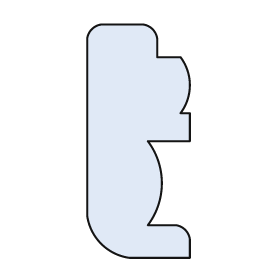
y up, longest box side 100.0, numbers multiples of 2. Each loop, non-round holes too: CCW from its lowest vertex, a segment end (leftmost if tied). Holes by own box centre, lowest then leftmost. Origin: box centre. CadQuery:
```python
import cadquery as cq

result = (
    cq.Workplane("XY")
    .moveTo(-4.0, -50.0)
    .lineTo(22.0, -50.0)
    .lineTo(22.0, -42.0)
    .threePointArc((20.0, -38.0), (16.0, -36.0))
    .lineTo(4.0, -36.0)
    .threePointArc((10.0, -18.0), (4.0, 0.0))
    .lineTo(22.0, 0.0)
    .lineTo(22.0, 12.0)
    .lineTo(18.0, 12.0)
    .threePointArc((22.0, 24.0), (18.0, 36.0))
    .lineTo(8.0, 36.0)
    .lineTo(8.0, 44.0)
    .threePointArc((6.0, 48.0), (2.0, 50.0))
    .lineTo(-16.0, 50.0)
    .threePointArc((-20.0, 48.0), (-22.0, 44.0))
    .lineTo(-22.0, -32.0)
    .threePointArc((-16.0, -44.0), (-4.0, -50.0))
    .close()
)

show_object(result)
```